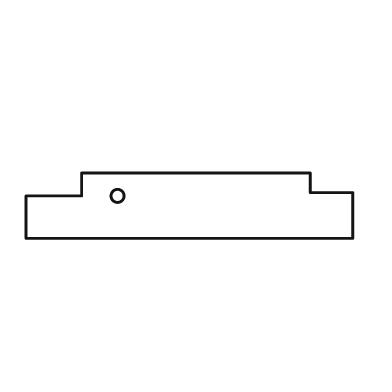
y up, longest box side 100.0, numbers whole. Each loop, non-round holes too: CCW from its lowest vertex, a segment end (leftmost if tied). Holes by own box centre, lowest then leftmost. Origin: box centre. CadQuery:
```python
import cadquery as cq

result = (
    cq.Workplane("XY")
    .moveTo(-50.0, -10.0)
    .lineTo(50.0, -10.0)
    .lineTo(50.0, 4.0)
    .lineTo(37.0, 4.0)
    .lineTo(37.0, 10.0)
    .lineTo(-33.0, 10.0)
    .lineTo(-33.0, 3.0)
    .lineTo(-50.0, 3.0)
    .close()
    .moveTo(-22.0, 3.0)
    .circle(2.0)
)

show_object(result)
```